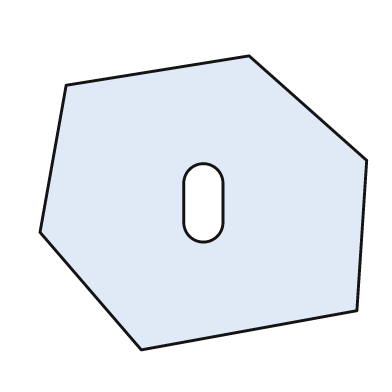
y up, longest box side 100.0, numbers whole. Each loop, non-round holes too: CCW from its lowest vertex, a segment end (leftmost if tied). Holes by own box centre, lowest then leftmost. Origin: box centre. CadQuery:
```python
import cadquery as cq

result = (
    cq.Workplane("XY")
    .moveTo(-19.0, -45.0)
    .lineTo(47.0, -33.0)
    .lineTo(50.0, 13.0)
    .lineTo(14.0, 45.0)
    .lineTo(-42.0, 36.0)
    .lineTo(-50.0, -9.0)
    .close()
    .moveTo(-6.0, -6.0)
    .threePointArc((0.0, -12.0), (6.0, -6.0))
    .lineTo(6.0, 6.0)
    .threePointArc((0.0, 12.0), (-6.0, 6.0))
    .close()
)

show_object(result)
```